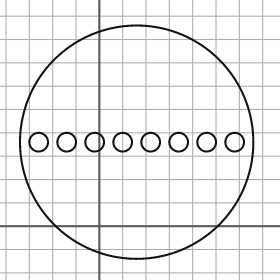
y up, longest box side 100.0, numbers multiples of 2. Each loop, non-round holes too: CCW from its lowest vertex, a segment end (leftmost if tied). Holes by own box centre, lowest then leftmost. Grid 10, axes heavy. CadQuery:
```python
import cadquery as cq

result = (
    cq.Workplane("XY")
    .moveTo(16.0, 36.0)
    .circle(50.0)
    .moveTo(-26.0, 36.0)
    .circle(4.0)
    .moveTo(-14.0, 36.0)
    .circle(4.0)
    .moveTo(-2.0, 36.0)
    .circle(4.0)
    .moveTo(10.0, 36.0)
    .circle(4.0)
    .moveTo(22.0, 36.0)
    .circle(4.0)
    .moveTo(34.0, 36.0)
    .circle(4.0)
    .moveTo(46.0, 36.0)
    .circle(4.0)
    .moveTo(58.0, 36.0)
    .circle(4.0)
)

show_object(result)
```